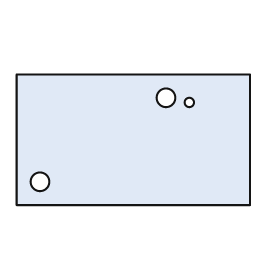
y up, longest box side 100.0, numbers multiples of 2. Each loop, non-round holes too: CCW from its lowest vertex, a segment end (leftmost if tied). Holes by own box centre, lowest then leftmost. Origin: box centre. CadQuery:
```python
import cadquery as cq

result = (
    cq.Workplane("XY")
    .moveTo(-50.0, -28.0)
    .lineTo(50.0, -28.0)
    .lineTo(50.0, 28.0)
    .lineTo(-50.0, 28.0)
    .close()
    .moveTo(-40.0, -18.0)
    .circle(4.0)
    .moveTo(24.0, 16.0)
    .circle(2.0)
    .moveTo(14.0, 18.0)
    .circle(4.0)
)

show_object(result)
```